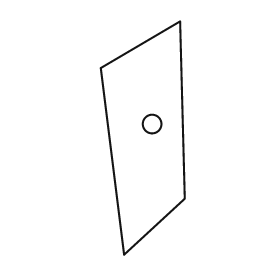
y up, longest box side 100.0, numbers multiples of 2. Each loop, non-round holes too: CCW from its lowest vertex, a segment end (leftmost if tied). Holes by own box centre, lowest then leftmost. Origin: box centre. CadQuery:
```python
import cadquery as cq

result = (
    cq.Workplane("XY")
    .moveTo(-8.0, -50.0)
    .lineTo(18.0, -26.0)
    .lineTo(16.0, 50.0)
    .lineTo(-18.0, 30.0)
    .close()
    .moveTo(4.0, 6.0)
    .circle(4.0)
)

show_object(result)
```